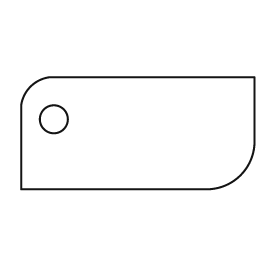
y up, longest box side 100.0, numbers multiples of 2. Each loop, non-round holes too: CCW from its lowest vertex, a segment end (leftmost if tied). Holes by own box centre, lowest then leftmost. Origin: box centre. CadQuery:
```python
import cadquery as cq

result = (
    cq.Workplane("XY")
    .moveTo(-50.0, -24.0)
    .lineTo(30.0, -24.0)
    .threePointArc((44.0, -18.0), (50.0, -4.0))
    .lineTo(50.0, 24.0)
    .lineTo(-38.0, 24.0)
    .threePointArc((-46.0, 20.0), (-50.0, 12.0))
    .close()
    .moveTo(-36.0, 6.0)
    .circle(6.0)
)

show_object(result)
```